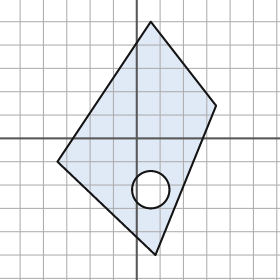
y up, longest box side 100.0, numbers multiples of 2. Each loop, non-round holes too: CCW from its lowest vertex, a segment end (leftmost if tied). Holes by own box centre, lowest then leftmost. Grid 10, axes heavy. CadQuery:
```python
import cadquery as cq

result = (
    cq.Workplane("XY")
    .moveTo(8.0, -50.0)
    .lineTo(34.0, 14.0)
    .lineTo(6.0, 50.0)
    .lineTo(-34.0, -10.0)
    .close()
    .moveTo(6.0, -22.0)
    .circle(8.0)
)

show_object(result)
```